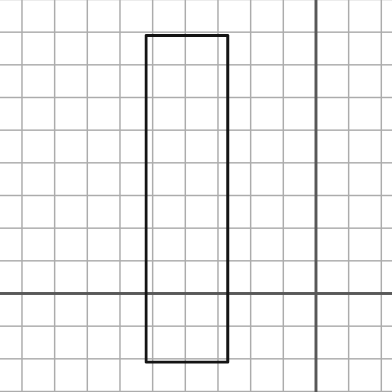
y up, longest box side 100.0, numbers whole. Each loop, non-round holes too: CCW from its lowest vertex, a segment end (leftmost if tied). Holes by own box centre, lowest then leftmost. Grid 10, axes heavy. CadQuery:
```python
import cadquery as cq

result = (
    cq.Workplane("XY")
    .moveTo(-52.0, -21.0)
    .lineTo(-27.0, -21.0)
    .lineTo(-27.0, 79.0)
    .lineTo(-52.0, 79.0)
    .close()
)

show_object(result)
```